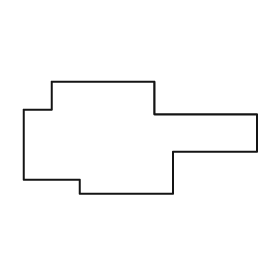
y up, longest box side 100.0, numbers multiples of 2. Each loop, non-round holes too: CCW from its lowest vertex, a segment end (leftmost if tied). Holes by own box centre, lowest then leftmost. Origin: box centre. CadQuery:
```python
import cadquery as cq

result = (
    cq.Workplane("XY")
    .moveTo(-26.0, -24.0)
    .lineTo(14.0, -24.0)
    .lineTo(14.0, -6.0)
    .lineTo(50.0, -6.0)
    .lineTo(50.0, 10.0)
    .lineTo(6.0, 10.0)
    .lineTo(6.0, 24.0)
    .lineTo(-38.0, 24.0)
    .lineTo(-38.0, 12.0)
    .lineTo(-50.0, 12.0)
    .lineTo(-50.0, -18.0)
    .lineTo(-26.0, -18.0)
    .close()
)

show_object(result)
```